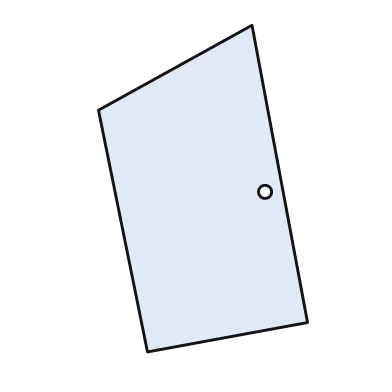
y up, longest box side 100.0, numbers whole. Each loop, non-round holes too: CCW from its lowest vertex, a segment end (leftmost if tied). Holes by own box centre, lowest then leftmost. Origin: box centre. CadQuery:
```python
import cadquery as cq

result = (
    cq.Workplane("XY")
    .moveTo(-17.0, -50.0)
    .lineTo(32.0, -41.0)
    .lineTo(15.0, 50.0)
    .lineTo(-32.0, 24.0)
    .close()
    .moveTo(19.0, -1.0)
    .circle(2.0)
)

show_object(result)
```